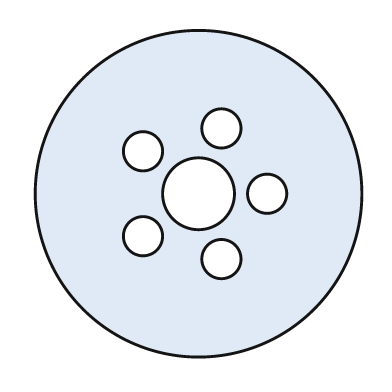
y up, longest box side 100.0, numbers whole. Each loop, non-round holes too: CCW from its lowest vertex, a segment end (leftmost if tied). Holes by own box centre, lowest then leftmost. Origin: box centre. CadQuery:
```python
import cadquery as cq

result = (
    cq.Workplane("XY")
    .moveTo(0.0, 0.0)
    .circle(50.0)
    .moveTo(7.0, -20.0)
    .circle(6.0)
    .moveTo(-17.0, -13.0)
    .circle(6.0)
    .moveTo(0.0, 0.0)
    .circle(11.0)
    .moveTo(21.0, 0.0)
    .circle(6.0)
    .moveTo(-17.0, 13.0)
    .circle(6.0)
    .moveTo(7.0, 20.0)
    .circle(6.0)
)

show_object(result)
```